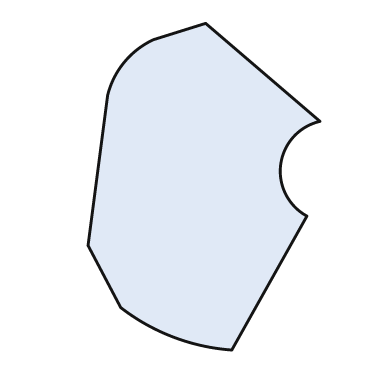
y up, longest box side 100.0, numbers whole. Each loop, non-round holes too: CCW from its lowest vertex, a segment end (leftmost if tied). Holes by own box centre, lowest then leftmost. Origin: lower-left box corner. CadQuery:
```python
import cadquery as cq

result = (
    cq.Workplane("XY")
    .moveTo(44.0, 0.0)
    .lineTo(67.0, 41.0)
    .threePointArc((59.0, 57.0), (71.0, 70.0))
    .lineTo(36.0, 100.0)
    .lineTo(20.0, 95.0)
    .threePointArc((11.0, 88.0), (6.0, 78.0))
    .lineTo(0.0, 32.0)
    .lineTo(10.0, 13.0)
    .threePointArc((26.0, 4.0), (44.0, 0.0))
    .close()
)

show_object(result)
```